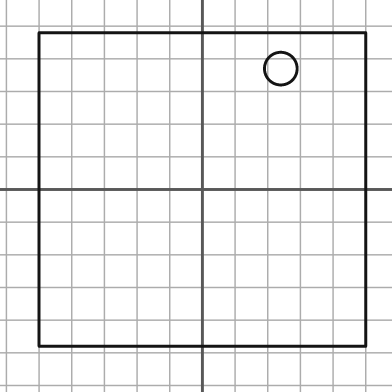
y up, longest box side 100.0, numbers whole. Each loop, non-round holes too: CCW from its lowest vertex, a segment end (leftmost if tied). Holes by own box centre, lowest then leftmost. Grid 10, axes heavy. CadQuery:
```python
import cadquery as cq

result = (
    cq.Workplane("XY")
    .moveTo(-50.0, -48.0)
    .lineTo(50.0, -48.0)
    .lineTo(50.0, 48.0)
    .lineTo(-50.0, 48.0)
    .close()
    .moveTo(24.0, 37.0)
    .circle(5.0)
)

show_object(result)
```